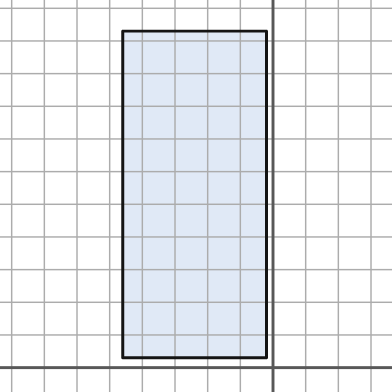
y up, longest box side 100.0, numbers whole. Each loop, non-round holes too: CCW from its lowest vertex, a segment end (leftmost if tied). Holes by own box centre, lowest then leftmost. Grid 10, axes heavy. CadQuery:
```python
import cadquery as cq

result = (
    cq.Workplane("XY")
    .moveTo(-46.0, 3.0)
    .lineTo(-2.0, 3.0)
    .lineTo(-2.0, 103.0)
    .lineTo(-46.0, 103.0)
    .close()
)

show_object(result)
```